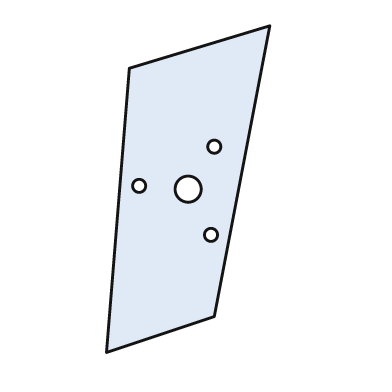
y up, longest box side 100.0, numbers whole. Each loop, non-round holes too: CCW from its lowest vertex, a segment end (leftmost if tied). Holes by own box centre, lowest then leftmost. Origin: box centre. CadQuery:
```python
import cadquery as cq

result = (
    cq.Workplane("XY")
    .moveTo(-25.0, -50.0)
    .lineTo(8.0, -39.0)
    .lineTo(25.0, 50.0)
    .lineTo(-18.0, 37.0)
    .close()
    .moveTo(7.0, -14.0)
    .circle(2.0)
    .moveTo(0.0, 0.0)
    .circle(4.0)
    .moveTo(-15.0, 1.0)
    .circle(2.0)
    .moveTo(8.0, 13.0)
    .circle(2.0)
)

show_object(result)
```